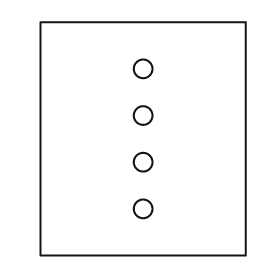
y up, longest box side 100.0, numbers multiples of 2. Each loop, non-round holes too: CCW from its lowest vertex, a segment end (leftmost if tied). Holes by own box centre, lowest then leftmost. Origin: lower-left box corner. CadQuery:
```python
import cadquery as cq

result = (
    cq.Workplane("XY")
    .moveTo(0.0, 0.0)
    .lineTo(88.0, 0.0)
    .lineTo(88.0, 100.0)
    .lineTo(0.0, 100.0)
    .close()
    .moveTo(44.0, 20.0)
    .circle(4.0)
    .moveTo(44.0, 40.0)
    .circle(4.0)
    .moveTo(44.0, 60.0)
    .circle(4.0)
    .moveTo(44.0, 80.0)
    .circle(4.0)
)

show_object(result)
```